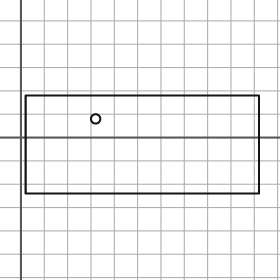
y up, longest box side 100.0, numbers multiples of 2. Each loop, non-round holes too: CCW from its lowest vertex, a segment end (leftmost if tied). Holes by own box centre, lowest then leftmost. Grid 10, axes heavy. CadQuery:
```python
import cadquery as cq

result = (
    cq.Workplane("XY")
    .moveTo(2.0, -24.0)
    .lineTo(102.0, -24.0)
    .lineTo(102.0, 18.0)
    .lineTo(2.0, 18.0)
    .close()
    .moveTo(32.0, 8.0)
    .circle(2.0)
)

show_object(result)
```